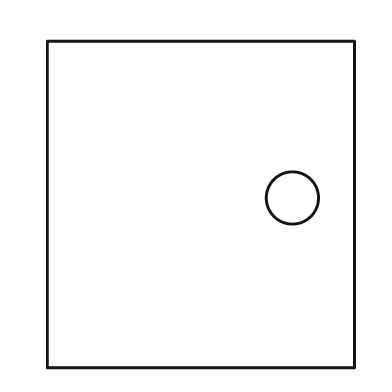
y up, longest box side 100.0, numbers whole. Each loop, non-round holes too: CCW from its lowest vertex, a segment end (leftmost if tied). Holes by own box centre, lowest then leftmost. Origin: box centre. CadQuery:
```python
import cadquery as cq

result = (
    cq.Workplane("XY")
    .moveTo(-47.0, -50.0)
    .lineTo(47.0, -50.0)
    .lineTo(47.0, 50.0)
    .lineTo(-47.0, 50.0)
    .close()
    .moveTo(28.0, 2.0)
    .circle(8.0)
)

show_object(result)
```